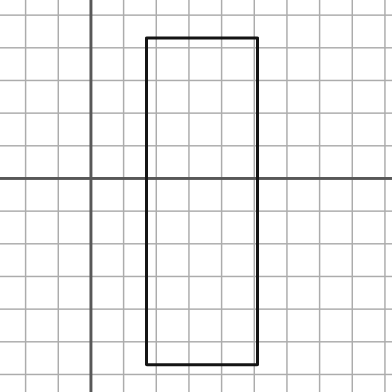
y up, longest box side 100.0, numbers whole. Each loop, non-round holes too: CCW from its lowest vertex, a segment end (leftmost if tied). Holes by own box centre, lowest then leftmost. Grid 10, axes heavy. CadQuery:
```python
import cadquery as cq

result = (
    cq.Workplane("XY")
    .moveTo(17.0, -57.0)
    .lineTo(51.0, -57.0)
    .lineTo(51.0, 43.0)
    .lineTo(17.0, 43.0)
    .close()
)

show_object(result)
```